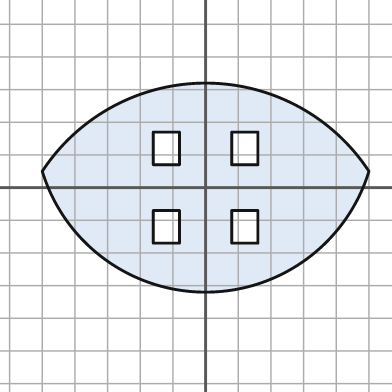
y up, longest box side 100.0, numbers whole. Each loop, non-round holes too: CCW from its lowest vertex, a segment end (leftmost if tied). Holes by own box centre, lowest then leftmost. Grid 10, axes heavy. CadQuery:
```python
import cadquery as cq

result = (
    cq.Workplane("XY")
    .moveTo(-50.0, 5.0)
    .threePointArc((0.0, -32.0), (50.0, 5.0))
    .threePointArc((0.0, 32.0), (-50.0, 5.0))
    .close()
    .moveTo(-16.0, -17.0)
    .lineTo(-8.0, -17.0)
    .lineTo(-8.0, -7.0)
    .lineTo(-16.0, -7.0)
    .close()
    .moveTo(8.0, -17.0)
    .lineTo(16.0, -17.0)
    .lineTo(16.0, -7.0)
    .lineTo(8.0, -7.0)
    .close()
    .moveTo(-16.0, 7.0)
    .lineTo(-8.0, 7.0)
    .lineTo(-8.0, 17.0)
    .lineTo(-16.0, 17.0)
    .close()
    .moveTo(8.0, 7.0)
    .lineTo(16.0, 7.0)
    .lineTo(16.0, 17.0)
    .lineTo(8.0, 17.0)
    .close()
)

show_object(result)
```